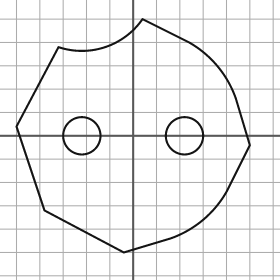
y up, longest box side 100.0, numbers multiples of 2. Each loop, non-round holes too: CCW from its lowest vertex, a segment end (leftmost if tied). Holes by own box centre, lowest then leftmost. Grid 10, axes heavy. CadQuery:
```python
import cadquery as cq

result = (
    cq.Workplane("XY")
    .moveTo(-4.0, -50.0)
    .lineTo(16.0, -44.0)
    .threePointArc((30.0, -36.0), (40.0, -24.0))
    .lineTo(50.0, -4.0)
    .lineTo(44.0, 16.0)
    .threePointArc((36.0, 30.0), (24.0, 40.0))
    .lineTo(4.0, 50.0)
    .threePointArc((-12.0, 38.0), (-32.0, 38.0))
    .lineTo(-50.0, 4.0)
    .lineTo(-38.0, -32.0)
    .close()
    .moveTo(-22.0, 0.0)
    .circle(8.0)
    .moveTo(22.0, 0.0)
    .circle(8.0)
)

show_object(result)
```